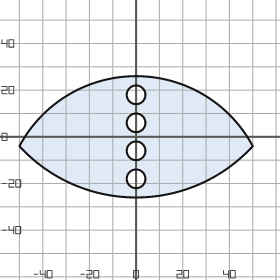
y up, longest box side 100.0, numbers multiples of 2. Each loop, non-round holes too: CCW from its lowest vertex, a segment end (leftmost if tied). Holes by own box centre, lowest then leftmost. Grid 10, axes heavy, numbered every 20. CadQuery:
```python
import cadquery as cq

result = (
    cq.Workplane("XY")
    .moveTo(-50.0, -4.0)
    .threePointArc((0.0, -26.0), (50.0, -4.0))
    .threePointArc((0.0, 26.0), (-50.0, -4.0))
    .close()
    .moveTo(0.0, -18.0)
    .circle(4.0)
    .moveTo(0.0, -6.0)
    .circle(4.0)
    .moveTo(0.0, 6.0)
    .circle(4.0)
    .moveTo(0.0, 18.0)
    .circle(4.0)
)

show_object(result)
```